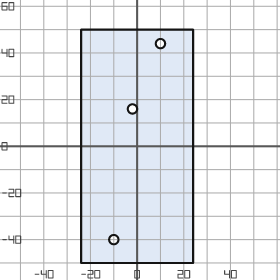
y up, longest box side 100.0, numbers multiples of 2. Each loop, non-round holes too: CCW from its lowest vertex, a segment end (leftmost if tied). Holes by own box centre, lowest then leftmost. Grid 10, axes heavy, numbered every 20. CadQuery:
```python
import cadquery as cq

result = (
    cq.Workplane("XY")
    .moveTo(-24.0, -50.0)
    .lineTo(24.0, -50.0)
    .lineTo(24.0, 50.0)
    .lineTo(-24.0, 50.0)
    .close()
    .moveTo(-10.0, -40.0)
    .circle(2.0)
    .moveTo(-2.0, 16.0)
    .circle(2.0)
    .moveTo(10.0, 44.0)
    .circle(2.0)
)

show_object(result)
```